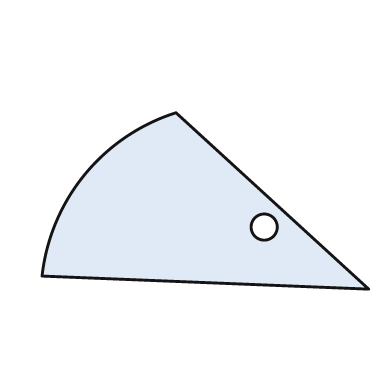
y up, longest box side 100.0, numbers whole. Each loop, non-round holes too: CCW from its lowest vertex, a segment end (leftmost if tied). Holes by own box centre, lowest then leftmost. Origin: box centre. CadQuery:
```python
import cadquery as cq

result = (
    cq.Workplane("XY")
    .moveTo(50.0, -27.0)
    .lineTo(-9.0, 27.0)
    .threePointArc((-37.0, 8.0), (-50.0, -23.0))
    .close()
    .moveTo(18.0, -8.0)
    .circle(4.0)
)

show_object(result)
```